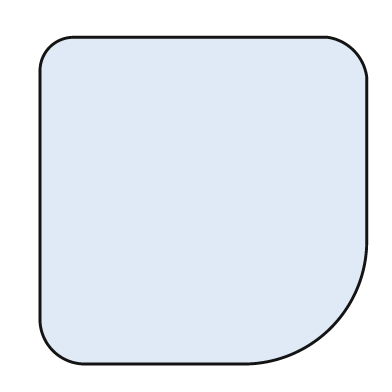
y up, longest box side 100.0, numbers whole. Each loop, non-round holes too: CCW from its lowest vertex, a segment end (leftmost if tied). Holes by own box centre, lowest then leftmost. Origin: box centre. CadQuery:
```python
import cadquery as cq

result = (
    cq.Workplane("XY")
    .moveTo(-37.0, -50.0)
    .lineTo(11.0, -50.0)
    .threePointArc((39.0, -39.0), (50.0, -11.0))
    .lineTo(50.0, 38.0)
    .threePointArc((46.0, 46.0), (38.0, 50.0))
    .lineTo(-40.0, 50.0)
    .threePointArc((-47.0, 47.0), (-50.0, 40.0))
    .lineTo(-50.0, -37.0)
    .threePointArc((-46.0, -46.0), (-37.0, -50.0))
    .close()
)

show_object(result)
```